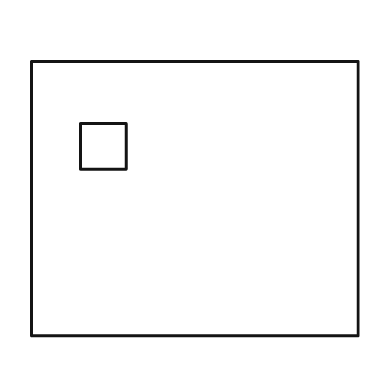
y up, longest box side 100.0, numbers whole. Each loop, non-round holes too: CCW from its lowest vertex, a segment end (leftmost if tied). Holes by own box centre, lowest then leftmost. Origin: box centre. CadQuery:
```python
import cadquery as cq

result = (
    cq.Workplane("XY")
    .moveTo(-50.0, -42.0)
    .lineTo(50.0, -42.0)
    .lineTo(50.0, 42.0)
    .lineTo(-50.0, 42.0)
    .close()
    .moveTo(-35.0, 9.0)
    .lineTo(-21.0, 9.0)
    .lineTo(-21.0, 23.0)
    .lineTo(-35.0, 23.0)
    .close()
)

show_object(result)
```